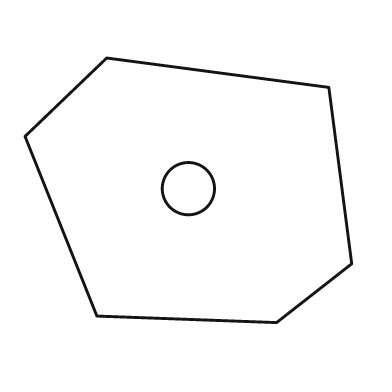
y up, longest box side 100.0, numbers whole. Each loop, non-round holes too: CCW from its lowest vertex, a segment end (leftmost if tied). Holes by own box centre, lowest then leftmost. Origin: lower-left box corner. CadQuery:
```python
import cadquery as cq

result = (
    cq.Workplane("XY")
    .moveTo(77.0, 0.0)
    .lineTo(100.0, 18.0)
    .lineTo(93.0, 72.0)
    .lineTo(25.0, 81.0)
    .lineTo(0.0, 57.0)
    .lineTo(22.0, 2.0)
    .close()
    .moveTo(50.0, 41.0)
    .circle(8.0)
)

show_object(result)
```